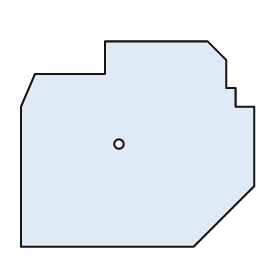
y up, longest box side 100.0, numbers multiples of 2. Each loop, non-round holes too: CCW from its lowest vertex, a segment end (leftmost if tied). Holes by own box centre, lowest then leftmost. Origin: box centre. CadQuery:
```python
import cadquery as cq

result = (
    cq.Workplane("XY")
    .moveTo(-50.0, -44.0)
    .lineTo(24.0, -44.0)
    .lineTo(50.0, -18.0)
    .lineTo(50.0, 16.0)
    .lineTo(42.0, 16.0)
    .lineTo(42.0, 24.0)
    .lineTo(38.0, 24.0)
    .lineTo(38.0, 36.0)
    .lineTo(30.0, 44.0)
    .lineTo(-14.0, 44.0)
    .lineTo(-14.0, 30.0)
    .lineTo(-44.0, 30.0)
    .lineTo(-50.0, 16.0)
    .close()
    .moveTo(-8.0, 0.0)
    .circle(2.0)
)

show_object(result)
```